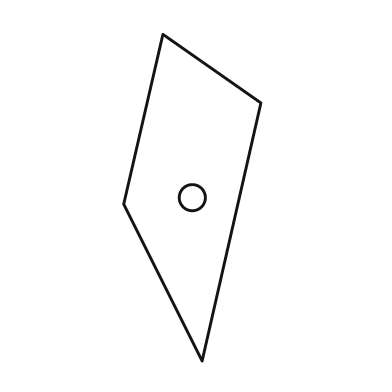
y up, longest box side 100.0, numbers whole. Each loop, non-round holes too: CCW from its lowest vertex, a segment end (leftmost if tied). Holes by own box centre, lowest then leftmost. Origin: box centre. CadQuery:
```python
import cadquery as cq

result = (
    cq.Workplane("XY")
    .moveTo(3.0, -50.0)
    .lineTo(21.0, 29.0)
    .lineTo(-9.0, 50.0)
    .lineTo(-21.0, -2.0)
    .close()
    .moveTo(0.0, 0.0)
    .circle(4.0)
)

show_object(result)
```